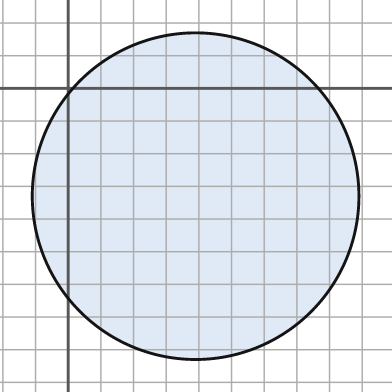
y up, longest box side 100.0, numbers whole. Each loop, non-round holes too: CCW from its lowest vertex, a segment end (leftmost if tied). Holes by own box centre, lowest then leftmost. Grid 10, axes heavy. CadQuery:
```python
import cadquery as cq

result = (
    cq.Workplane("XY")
    .moveTo(39.0, -33.0)
    .circle(50.0)
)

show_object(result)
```